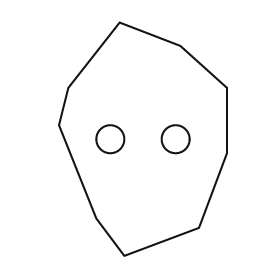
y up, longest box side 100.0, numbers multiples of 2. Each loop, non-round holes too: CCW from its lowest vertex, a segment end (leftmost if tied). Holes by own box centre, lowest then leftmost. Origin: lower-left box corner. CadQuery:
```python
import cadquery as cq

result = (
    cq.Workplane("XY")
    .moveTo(28.0, 0.0)
    .lineTo(60.0, 12.0)
    .lineTo(72.0, 44.0)
    .lineTo(72.0, 72.0)
    .lineTo(52.0, 90.0)
    .lineTo(26.0, 100.0)
    .lineTo(4.0, 72.0)
    .lineTo(0.0, 56.0)
    .lineTo(16.0, 16.0)
    .close()
    .moveTo(22.0, 50.0)
    .circle(6.0)
    .moveTo(50.0, 50.0)
    .circle(6.0)
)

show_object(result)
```